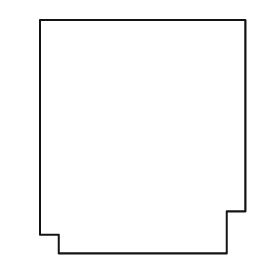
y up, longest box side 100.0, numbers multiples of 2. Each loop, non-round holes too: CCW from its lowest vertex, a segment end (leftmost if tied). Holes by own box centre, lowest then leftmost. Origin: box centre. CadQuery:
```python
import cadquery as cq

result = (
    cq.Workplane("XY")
    .moveTo(-36.0, -50.0)
    .lineTo(36.0, -50.0)
    .lineTo(36.0, -32.0)
    .lineTo(44.0, -32.0)
    .lineTo(44.0, 50.0)
    .lineTo(-44.0, 50.0)
    .lineTo(-44.0, -42.0)
    .lineTo(-36.0, -42.0)
    .close()
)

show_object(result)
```